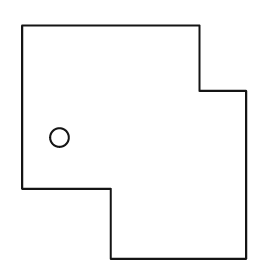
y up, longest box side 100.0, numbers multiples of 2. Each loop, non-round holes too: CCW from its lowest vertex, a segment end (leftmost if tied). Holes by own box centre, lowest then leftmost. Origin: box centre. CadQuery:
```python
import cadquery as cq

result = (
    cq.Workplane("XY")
    .moveTo(-10.0, -50.0)
    .lineTo(48.0, -50.0)
    .lineTo(48.0, 22.0)
    .lineTo(28.0, 22.0)
    .lineTo(28.0, 50.0)
    .lineTo(-48.0, 50.0)
    .lineTo(-48.0, -20.0)
    .lineTo(-10.0, -20.0)
    .close()
    .moveTo(-32.0, 2.0)
    .circle(4.0)
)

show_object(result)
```